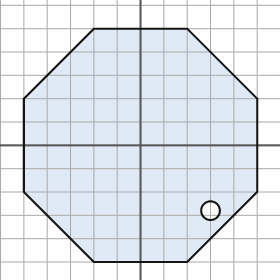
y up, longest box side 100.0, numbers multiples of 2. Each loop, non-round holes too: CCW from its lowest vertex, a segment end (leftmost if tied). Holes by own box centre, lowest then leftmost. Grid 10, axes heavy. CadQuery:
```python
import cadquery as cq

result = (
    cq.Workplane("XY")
    .moveTo(-20.0, -50.0)
    .lineTo(20.0, -50.0)
    .lineTo(50.0, -20.0)
    .lineTo(50.0, 20.0)
    .lineTo(20.0, 50.0)
    .lineTo(-20.0, 50.0)
    .lineTo(-50.0, 20.0)
    .lineTo(-50.0, -20.0)
    .close()
    .moveTo(30.0, -28.0)
    .circle(4.0)
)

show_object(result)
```